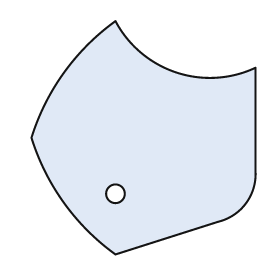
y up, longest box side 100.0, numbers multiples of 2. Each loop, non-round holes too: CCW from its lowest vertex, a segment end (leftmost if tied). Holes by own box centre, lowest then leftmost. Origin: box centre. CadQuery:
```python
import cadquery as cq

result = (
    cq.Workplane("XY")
    .moveTo(-12.0, -50.0)
    .lineTo(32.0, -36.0)
    .threePointArc((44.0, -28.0), (48.0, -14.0))
    .lineTo(48.0, 30.0)
    .threePointArc((14.0, 28.0), (-12.0, 50.0))
    .threePointArc((-34.0, 28.0), (-48.0, 0.0))
    .threePointArc((-34.0, -28.0), (-12.0, -50.0))
    .close()
    .moveTo(-12.0, -24.0)
    .circle(4.0)
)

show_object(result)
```